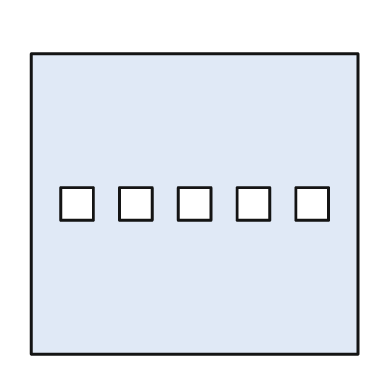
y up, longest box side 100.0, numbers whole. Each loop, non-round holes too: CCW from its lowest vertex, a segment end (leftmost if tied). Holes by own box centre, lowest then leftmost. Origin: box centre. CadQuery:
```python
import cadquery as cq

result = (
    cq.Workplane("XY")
    .moveTo(-50.0, -46.0)
    .lineTo(50.0, -46.0)
    .lineTo(50.0, 46.0)
    .lineTo(-50.0, 46.0)
    .close()
    .moveTo(-41.0, -5.0)
    .lineTo(-31.0, -5.0)
    .lineTo(-31.0, 5.0)
    .lineTo(-41.0, 5.0)
    .close()
    .moveTo(-23.0, -5.0)
    .lineTo(-13.0, -5.0)
    .lineTo(-13.0, 5.0)
    .lineTo(-23.0, 5.0)
    .close()
    .moveTo(-5.0, -5.0)
    .lineTo(5.0, -5.0)
    .lineTo(5.0, 5.0)
    .lineTo(-5.0, 5.0)
    .close()
    .moveTo(13.0, -5.0)
    .lineTo(23.0, -5.0)
    .lineTo(23.0, 5.0)
    .lineTo(13.0, 5.0)
    .close()
    .moveTo(31.0, -5.0)
    .lineTo(41.0, -5.0)
    .lineTo(41.0, 5.0)
    .lineTo(31.0, 5.0)
    .close()
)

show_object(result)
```